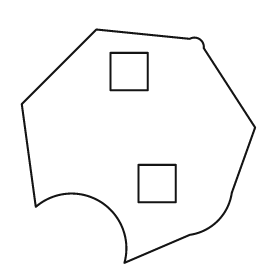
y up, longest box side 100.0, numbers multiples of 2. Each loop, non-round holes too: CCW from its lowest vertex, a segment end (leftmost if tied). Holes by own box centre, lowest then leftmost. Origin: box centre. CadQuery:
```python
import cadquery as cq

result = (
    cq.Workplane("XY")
    .moveTo(-6.0, -50.0)
    .lineTo(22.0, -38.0)
    .threePointArc((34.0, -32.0), (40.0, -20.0))
    .lineTo(50.0, 8.0)
    .lineTo(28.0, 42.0)
    .threePointArc((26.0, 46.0), (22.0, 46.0))
    .lineTo(-18.0, 50.0)
    .lineTo(-50.0, 18.0)
    .lineTo(-44.0, -26.0)
    .threePointArc((-16.0, -24.0), (-6.0, -50.0))
    .close()
    .moveTo(0.0, -24.0)
    .lineTo(16.0, -24.0)
    .lineTo(16.0, -8.0)
    .lineTo(0.0, -8.0)
    .close()
    .moveTo(-12.0, 24.0)
    .lineTo(4.0, 24.0)
    .lineTo(4.0, 40.0)
    .lineTo(-12.0, 40.0)
    .close()
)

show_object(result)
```